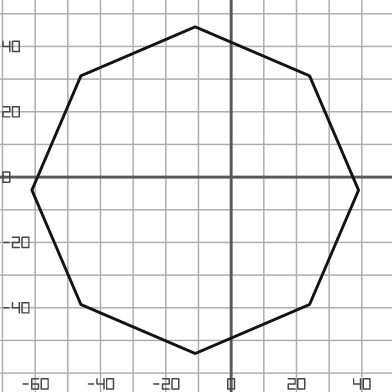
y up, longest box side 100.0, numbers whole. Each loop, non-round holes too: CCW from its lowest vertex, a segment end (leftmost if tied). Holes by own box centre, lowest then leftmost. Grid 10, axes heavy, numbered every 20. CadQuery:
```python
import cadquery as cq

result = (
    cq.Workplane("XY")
    .moveTo(-11.0, -54.0)
    .lineTo(24.0, -39.0)
    .lineTo(39.0, -4.0)
    .lineTo(24.0, 31.0)
    .lineTo(-11.0, 46.0)
    .lineTo(-46.0, 31.0)
    .lineTo(-61.0, -4.0)
    .lineTo(-46.0, -39.0)
    .close()
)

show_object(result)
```